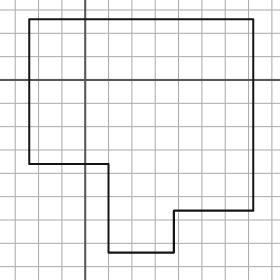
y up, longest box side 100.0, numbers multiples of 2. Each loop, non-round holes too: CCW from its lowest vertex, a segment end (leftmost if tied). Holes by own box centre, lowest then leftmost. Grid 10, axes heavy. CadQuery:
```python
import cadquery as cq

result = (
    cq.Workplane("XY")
    .moveTo(10.0, -74.0)
    .lineTo(38.0, -74.0)
    .lineTo(38.0, -56.0)
    .lineTo(72.0, -56.0)
    .lineTo(72.0, 26.0)
    .lineTo(-24.0, 26.0)
    .lineTo(-24.0, -36.0)
    .lineTo(10.0, -36.0)
    .close()
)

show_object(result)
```